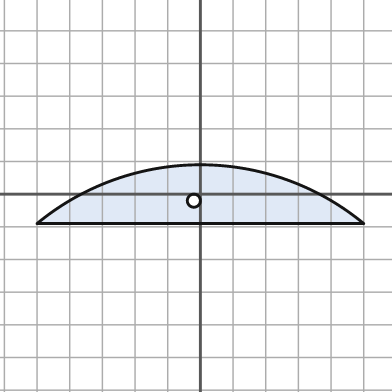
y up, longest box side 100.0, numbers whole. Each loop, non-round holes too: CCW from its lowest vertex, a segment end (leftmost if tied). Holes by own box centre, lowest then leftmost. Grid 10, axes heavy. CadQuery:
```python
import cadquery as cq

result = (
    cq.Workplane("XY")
    .moveTo(-50.0, -9.0)
    .lineTo(50.0, -9.0)
    .threePointArc((0.0, 9.0), (-50.0, -9.0))
    .close()
    .moveTo(-2.0, -2.0)
    .circle(2.0)
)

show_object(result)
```